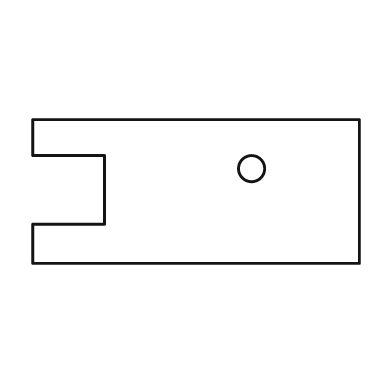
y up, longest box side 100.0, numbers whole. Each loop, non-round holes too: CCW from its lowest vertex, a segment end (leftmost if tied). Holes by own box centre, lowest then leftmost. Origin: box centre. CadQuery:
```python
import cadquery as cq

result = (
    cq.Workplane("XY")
    .moveTo(-50.0, -22.0)
    .lineTo(50.0, -22.0)
    .lineTo(50.0, 22.0)
    .lineTo(-50.0, 22.0)
    .lineTo(-50.0, 11.0)
    .lineTo(-28.0, 11.0)
    .lineTo(-28.0, -10.0)
    .lineTo(-50.0, -10.0)
    .close()
    .moveTo(17.0, 7.0)
    .circle(4.0)
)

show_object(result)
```